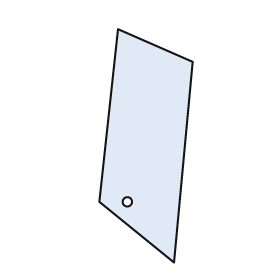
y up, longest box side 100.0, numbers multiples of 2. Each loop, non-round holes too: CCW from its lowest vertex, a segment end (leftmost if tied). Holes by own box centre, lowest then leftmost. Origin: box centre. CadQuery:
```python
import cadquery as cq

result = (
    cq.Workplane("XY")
    .moveTo(12.0, -50.0)
    .lineTo(20.0, 36.0)
    .lineTo(-12.0, 50.0)
    .lineTo(-20.0, -24.0)
    .close()
    .moveTo(-8.0, -24.0)
    .circle(2.0)
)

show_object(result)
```